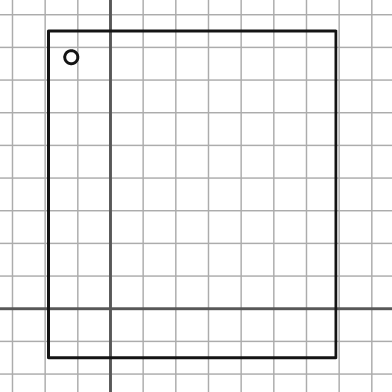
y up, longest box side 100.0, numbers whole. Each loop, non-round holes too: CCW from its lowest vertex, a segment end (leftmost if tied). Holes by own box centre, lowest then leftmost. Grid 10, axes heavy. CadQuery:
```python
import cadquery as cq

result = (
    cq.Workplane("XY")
    .moveTo(-19.0, -15.0)
    .lineTo(69.0, -15.0)
    .lineTo(69.0, 85.0)
    .lineTo(-19.0, 85.0)
    .close()
    .moveTo(-12.0, 77.0)
    .circle(2.0)
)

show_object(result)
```